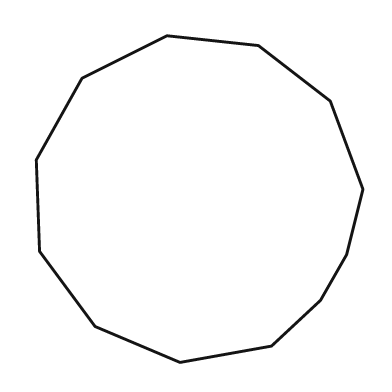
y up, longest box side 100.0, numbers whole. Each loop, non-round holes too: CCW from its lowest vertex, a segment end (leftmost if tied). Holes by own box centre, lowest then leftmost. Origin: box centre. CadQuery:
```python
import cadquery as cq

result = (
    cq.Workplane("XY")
    .moveTo(-6.0, -50.0)
    .lineTo(22.0, -45.0)
    .lineTo(37.0, -31.0)
    .lineTo(45.0, -17.0)
    .lineTo(50.0, 3.0)
    .lineTo(40.0, 30.0)
    .lineTo(18.0, 47.0)
    .lineTo(-10.0, 50.0)
    .lineTo(-36.0, 37.0)
    .lineTo(-50.0, 12.0)
    .lineTo(-49.0, -16.0)
    .lineTo(-32.0, -39.0)
    .close()
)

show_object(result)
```